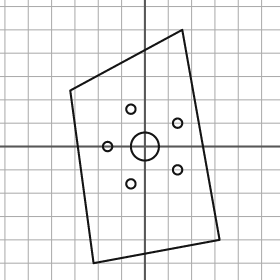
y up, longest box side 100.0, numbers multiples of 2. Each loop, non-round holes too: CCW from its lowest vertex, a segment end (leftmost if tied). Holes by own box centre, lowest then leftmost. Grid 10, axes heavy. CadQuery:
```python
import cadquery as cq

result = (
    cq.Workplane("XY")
    .moveTo(-22.0, -50.0)
    .lineTo(32.0, -40.0)
    .lineTo(16.0, 50.0)
    .lineTo(-32.0, 24.0)
    .close()
    .moveTo(-6.0, -16.0)
    .circle(2.0)
    .moveTo(14.0, -10.0)
    .circle(2.0)
    .moveTo(-16.0, 0.0)
    .circle(2.0)
    .moveTo(0.0, 0.0)
    .circle(6.0)
    .moveTo(14.0, 10.0)
    .circle(2.0)
    .moveTo(-6.0, 16.0)
    .circle(2.0)
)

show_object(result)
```